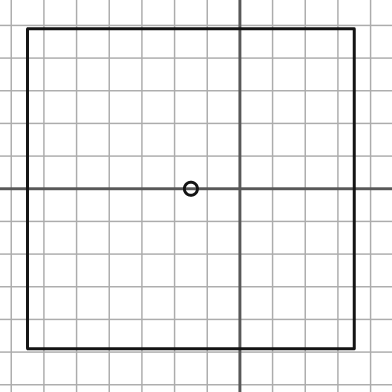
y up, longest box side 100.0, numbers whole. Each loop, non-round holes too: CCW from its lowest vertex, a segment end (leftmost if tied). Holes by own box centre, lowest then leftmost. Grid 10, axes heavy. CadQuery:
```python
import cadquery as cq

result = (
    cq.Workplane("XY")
    .moveTo(-65.0, -49.0)
    .lineTo(35.0, -49.0)
    .lineTo(35.0, 49.0)
    .lineTo(-65.0, 49.0)
    .close()
    .moveTo(-15.0, 0.0)
    .circle(2.0)
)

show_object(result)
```